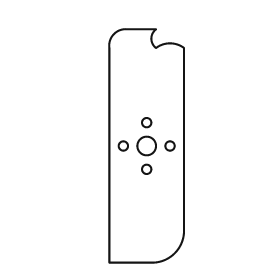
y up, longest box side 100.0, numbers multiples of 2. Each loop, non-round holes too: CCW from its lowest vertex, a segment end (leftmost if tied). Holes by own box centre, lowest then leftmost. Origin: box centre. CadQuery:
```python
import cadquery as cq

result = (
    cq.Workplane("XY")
    .moveTo(-16.0, -50.0)
    .lineTo(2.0, -50.0)
    .threePointArc((12.0, -46.0), (16.0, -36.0))
    .lineTo(16.0, 42.0)
    .threePointArc((10.0, 44.0), (4.0, 42.0))
    .threePointArc((2.0, 46.0), (4.0, 50.0))
    .lineTo(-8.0, 50.0)
    .threePointArc((-14.0, 48.0), (-16.0, 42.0))
    .close()
    .moveTo(0.0, -10.0)
    .circle(2.0)
    .moveTo(-10.0, 0.0)
    .circle(2.0)
    .moveTo(0.0, 0.0)
    .circle(4.0)
    .moveTo(10.0, 0.0)
    .circle(2.0)
    .moveTo(0.0, 10.0)
    .circle(2.0)
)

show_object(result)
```